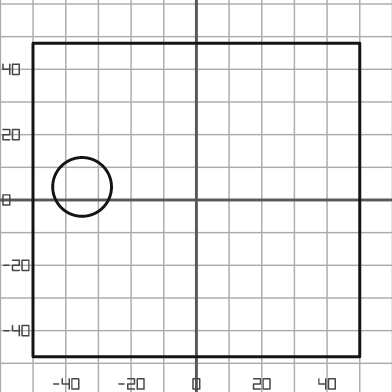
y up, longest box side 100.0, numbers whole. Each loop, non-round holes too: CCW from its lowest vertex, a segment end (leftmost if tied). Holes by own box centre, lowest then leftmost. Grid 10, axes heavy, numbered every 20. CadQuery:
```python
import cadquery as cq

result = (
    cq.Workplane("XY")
    .moveTo(-50.0, -48.0)
    .lineTo(50.0, -48.0)
    .lineTo(50.0, 48.0)
    .lineTo(-50.0, 48.0)
    .close()
    .moveTo(-35.0, 4.0)
    .circle(9.0)
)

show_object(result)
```